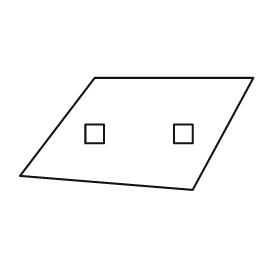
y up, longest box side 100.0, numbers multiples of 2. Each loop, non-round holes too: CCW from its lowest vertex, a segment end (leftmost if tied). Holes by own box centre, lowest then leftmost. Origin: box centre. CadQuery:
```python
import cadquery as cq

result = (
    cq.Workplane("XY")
    .moveTo(24.0, -24.0)
    .lineTo(50.0, 24.0)
    .lineTo(-18.0, 24.0)
    .lineTo(-50.0, -18.0)
    .close()
    .moveTo(-22.0, -4.0)
    .lineTo(-14.0, -4.0)
    .lineTo(-14.0, 4.0)
    .lineTo(-22.0, 4.0)
    .close()
    .moveTo(16.0, -4.0)
    .lineTo(24.0, -4.0)
    .lineTo(24.0, 4.0)
    .lineTo(16.0, 4.0)
    .close()
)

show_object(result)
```